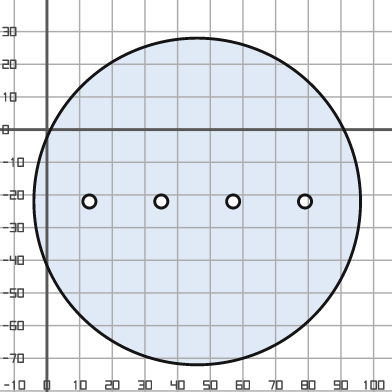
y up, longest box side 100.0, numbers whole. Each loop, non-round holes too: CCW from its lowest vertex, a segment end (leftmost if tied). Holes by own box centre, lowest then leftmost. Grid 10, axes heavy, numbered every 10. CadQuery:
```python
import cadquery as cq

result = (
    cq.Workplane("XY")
    .moveTo(46.0, -22.0)
    .circle(50.0)
    .moveTo(13.0, -22.0)
    .circle(2.0)
    .moveTo(35.0, -22.0)
    .circle(2.0)
    .moveTo(57.0, -22.0)
    .circle(2.0)
    .moveTo(79.0, -22.0)
    .circle(2.0)
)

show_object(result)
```